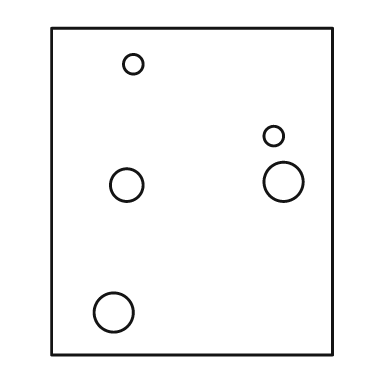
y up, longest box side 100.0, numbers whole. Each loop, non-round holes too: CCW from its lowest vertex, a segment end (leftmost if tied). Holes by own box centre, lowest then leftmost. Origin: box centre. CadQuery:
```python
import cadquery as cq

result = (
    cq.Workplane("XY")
    .moveTo(-43.0, -50.0)
    .lineTo(43.0, -50.0)
    .lineTo(43.0, 50.0)
    .lineTo(-43.0, 50.0)
    .close()
    .moveTo(-24.0, -37.0)
    .circle(6.0)
    .moveTo(-20.0, 2.0)
    .circle(5.0)
    .moveTo(28.0, 3.0)
    .circle(6.0)
    .moveTo(25.0, 17.0)
    .circle(3.0)
    .moveTo(-18.0, 39.0)
    .circle(3.0)
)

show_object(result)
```